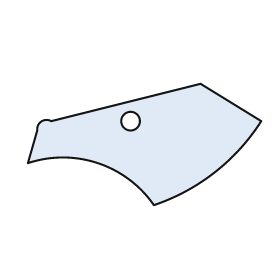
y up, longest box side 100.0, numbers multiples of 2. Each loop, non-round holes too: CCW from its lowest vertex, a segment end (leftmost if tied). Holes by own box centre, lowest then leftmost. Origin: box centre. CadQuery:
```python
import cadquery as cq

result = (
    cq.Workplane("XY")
    .moveTo(4.0, -26.0)
    .threePointArc((30.0, -12.0), (50.0, 10.0))
    .lineTo(24.0, 26.0)
    .lineTo(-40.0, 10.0)
    .threePointArc((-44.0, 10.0), (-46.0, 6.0))
    .lineTo(-50.0, -8.0)
    .threePointArc((-20.0, -8.0), (4.0, -26.0))
    .close()
    .moveTo(-6.0, 10.0)
    .circle(4.0)
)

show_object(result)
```